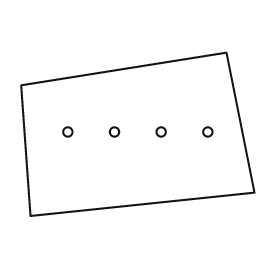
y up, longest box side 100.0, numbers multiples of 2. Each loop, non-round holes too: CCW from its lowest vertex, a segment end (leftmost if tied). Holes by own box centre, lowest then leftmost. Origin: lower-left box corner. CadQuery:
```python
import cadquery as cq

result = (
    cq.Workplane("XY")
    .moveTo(4.0, 0.0)
    .lineTo(100.0, 10.0)
    .lineTo(88.0, 70.0)
    .lineTo(0.0, 56.0)
    .close()
    .moveTo(20.0, 36.0)
    .circle(2.0)
    .moveTo(40.0, 36.0)
    .circle(2.0)
    .moveTo(60.0, 36.0)
    .circle(2.0)
    .moveTo(80.0, 36.0)
    .circle(2.0)
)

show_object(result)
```